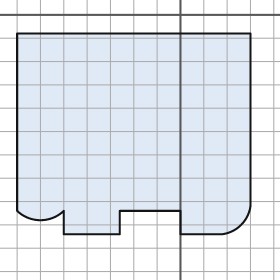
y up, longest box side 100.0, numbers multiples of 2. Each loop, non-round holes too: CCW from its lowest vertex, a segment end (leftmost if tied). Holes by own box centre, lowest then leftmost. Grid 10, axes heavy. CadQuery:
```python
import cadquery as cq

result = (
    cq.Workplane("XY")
    .moveTo(-50.0, -94.0)
    .lineTo(-26.0, -94.0)
    .lineTo(-26.0, -84.0)
    .lineTo(0.0, -84.0)
    .lineTo(0.0, -94.0)
    .lineTo(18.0, -94.0)
    .threePointArc((26.0, -90.0), (30.0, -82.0))
    .lineTo(30.0, -8.0)
    .lineTo(-70.0, -8.0)
    .lineTo(-70.0, -84.0)
    .threePointArc((-60.0, -88.0), (-50.0, -84.0))
    .close()
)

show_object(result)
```